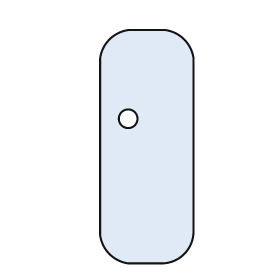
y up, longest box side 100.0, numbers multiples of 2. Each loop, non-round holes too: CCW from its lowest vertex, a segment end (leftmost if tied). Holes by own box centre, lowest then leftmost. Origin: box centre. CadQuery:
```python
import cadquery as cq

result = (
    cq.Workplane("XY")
    .moveTo(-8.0, -50.0)
    .lineTo(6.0, -50.0)
    .threePointArc((16.0, -46.0), (20.0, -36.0))
    .lineTo(20.0, 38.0)
    .threePointArc((16.0, 46.0), (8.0, 50.0))
    .lineTo(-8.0, 50.0)
    .threePointArc((-16.0, 46.0), (-20.0, 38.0))
    .lineTo(-20.0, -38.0)
    .threePointArc((-16.0, -46.0), (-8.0, -50.0))
    .close()
    .moveTo(-8.0, 12.0)
    .circle(4.0)
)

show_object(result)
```